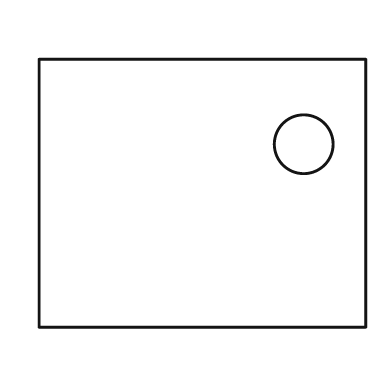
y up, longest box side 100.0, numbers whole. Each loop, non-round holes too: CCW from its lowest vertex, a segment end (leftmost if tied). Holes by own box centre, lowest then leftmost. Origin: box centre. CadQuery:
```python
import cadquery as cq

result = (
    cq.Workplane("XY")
    .moveTo(-50.0, -41.0)
    .lineTo(50.0, -41.0)
    .lineTo(50.0, 41.0)
    .lineTo(-50.0, 41.0)
    .close()
    .moveTo(31.0, 15.0)
    .circle(9.0)
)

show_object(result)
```